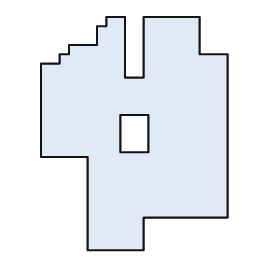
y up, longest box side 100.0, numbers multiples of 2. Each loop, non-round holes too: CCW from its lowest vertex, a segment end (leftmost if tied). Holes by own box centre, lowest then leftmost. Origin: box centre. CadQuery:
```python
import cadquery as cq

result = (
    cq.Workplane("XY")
    .moveTo(-20.0, -50.0)
    .lineTo(4.0, -50.0)
    .lineTo(4.0, -36.0)
    .lineTo(40.0, -36.0)
    .lineTo(40.0, 34.0)
    .lineTo(28.0, 34.0)
    .lineTo(28.0, 50.0)
    .lineTo(4.0, 50.0)
    .lineTo(4.0, 24.0)
    .lineTo(-4.0, 24.0)
    .lineTo(-4.0, 50.0)
    .lineTo(-12.0, 50.0)
    .lineTo(-12.0, 46.0)
    .lineTo(-16.0, 46.0)
    .lineTo(-16.0, 38.0)
    .lineTo(-28.0, 38.0)
    .lineTo(-28.0, 34.0)
    .lineTo(-32.0, 34.0)
    .lineTo(-32.0, 30.0)
    .lineTo(-40.0, 30.0)
    .lineTo(-40.0, -10.0)
    .lineTo(-20.0, -10.0)
    .close()
    .moveTo(-6.0, -8.0)
    .lineTo(6.0, -8.0)
    .lineTo(6.0, 8.0)
    .lineTo(-6.0, 8.0)
    .close()
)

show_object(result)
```